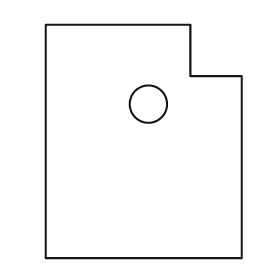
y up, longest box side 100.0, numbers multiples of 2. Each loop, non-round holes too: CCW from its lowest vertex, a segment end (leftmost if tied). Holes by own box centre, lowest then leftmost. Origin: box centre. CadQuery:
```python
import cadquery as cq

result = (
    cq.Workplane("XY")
    .moveTo(-42.0, -50.0)
    .lineTo(42.0, -50.0)
    .lineTo(42.0, 28.0)
    .lineTo(20.0, 28.0)
    .lineTo(20.0, 50.0)
    .lineTo(-42.0, 50.0)
    .close()
    .moveTo(2.0, 16.0)
    .circle(8.0)
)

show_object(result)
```